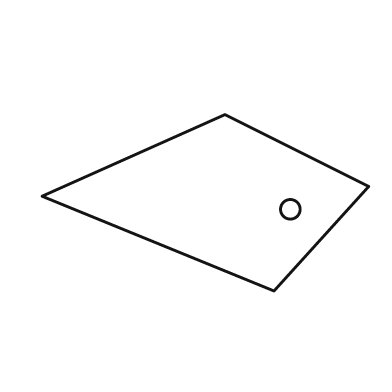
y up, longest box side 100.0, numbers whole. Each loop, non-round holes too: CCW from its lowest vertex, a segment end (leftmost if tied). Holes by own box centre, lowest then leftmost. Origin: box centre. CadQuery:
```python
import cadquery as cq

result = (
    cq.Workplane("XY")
    .moveTo(21.0, -27.0)
    .lineTo(50.0, 5.0)
    .lineTo(6.0, 27.0)
    .lineTo(-50.0, 2.0)
    .close()
    .moveTo(26.0, -2.0)
    .circle(3.0)
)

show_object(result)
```